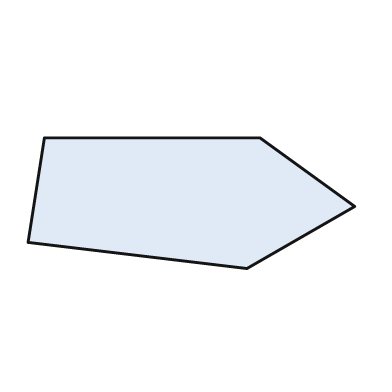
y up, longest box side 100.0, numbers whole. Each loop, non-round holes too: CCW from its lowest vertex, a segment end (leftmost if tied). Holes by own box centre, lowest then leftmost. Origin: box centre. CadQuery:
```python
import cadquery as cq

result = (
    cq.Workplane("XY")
    .moveTo(17.0, -20.0)
    .lineTo(50.0, -1.0)
    .lineTo(21.0, 20.0)
    .lineTo(-45.0, 20.0)
    .lineTo(-50.0, -12.0)
    .close()
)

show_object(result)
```